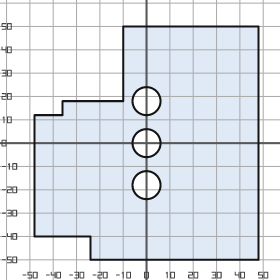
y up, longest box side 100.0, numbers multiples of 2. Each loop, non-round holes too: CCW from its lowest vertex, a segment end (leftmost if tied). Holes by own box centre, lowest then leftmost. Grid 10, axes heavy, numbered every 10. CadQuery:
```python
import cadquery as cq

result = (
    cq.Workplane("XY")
    .moveTo(-24.0, -50.0)
    .lineTo(48.0, -50.0)
    .lineTo(48.0, 50.0)
    .lineTo(-10.0, 50.0)
    .lineTo(-10.0, 18.0)
    .lineTo(-36.0, 18.0)
    .lineTo(-36.0, 12.0)
    .lineTo(-48.0, 12.0)
    .lineTo(-48.0, -40.0)
    .lineTo(-24.0, -40.0)
    .close()
    .moveTo(0.0, -18.0)
    .circle(6.0)
    .moveTo(0.0, 0.0)
    .circle(6.0)
    .moveTo(0.0, 18.0)
    .circle(6.0)
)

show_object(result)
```